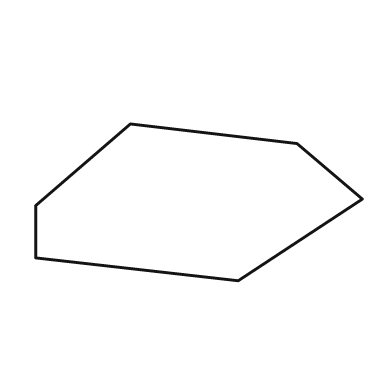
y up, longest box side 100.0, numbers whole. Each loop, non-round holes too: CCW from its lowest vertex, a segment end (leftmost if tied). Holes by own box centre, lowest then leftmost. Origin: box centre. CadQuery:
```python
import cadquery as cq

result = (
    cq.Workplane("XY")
    .moveTo(12.0, -24.0)
    .lineTo(50.0, 1.0)
    .lineTo(30.0, 18.0)
    .lineTo(-21.0, 24.0)
    .lineTo(-50.0, -1.0)
    .lineTo(-50.0, -17.0)
    .close()
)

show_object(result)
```